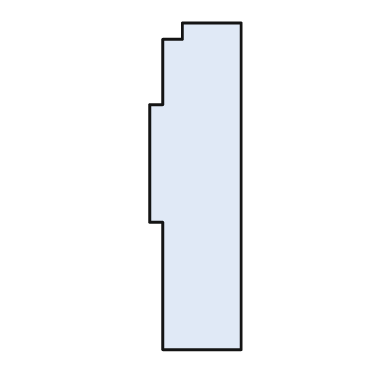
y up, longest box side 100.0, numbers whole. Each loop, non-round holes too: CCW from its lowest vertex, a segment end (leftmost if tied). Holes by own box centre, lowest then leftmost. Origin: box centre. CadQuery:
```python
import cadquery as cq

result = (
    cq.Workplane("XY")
    .moveTo(-10.0, -50.0)
    .lineTo(14.0, -50.0)
    .lineTo(14.0, 50.0)
    .lineTo(-4.0, 50.0)
    .lineTo(-4.0, 45.0)
    .lineTo(-10.0, 45.0)
    .lineTo(-10.0, 25.0)
    .lineTo(-14.0, 25.0)
    .lineTo(-14.0, -11.0)
    .lineTo(-10.0, -11.0)
    .close()
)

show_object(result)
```